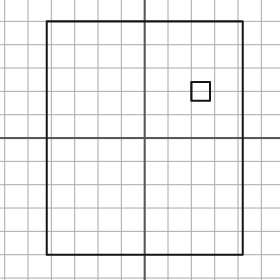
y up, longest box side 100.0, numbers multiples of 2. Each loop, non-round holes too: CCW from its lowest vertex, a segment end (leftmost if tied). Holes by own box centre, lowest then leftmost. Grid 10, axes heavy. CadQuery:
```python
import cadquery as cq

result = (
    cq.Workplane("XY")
    .moveTo(-42.0, -50.0)
    .lineTo(42.0, -50.0)
    .lineTo(42.0, 50.0)
    .lineTo(-42.0, 50.0)
    .close()
    .moveTo(20.0, 16.0)
    .lineTo(28.0, 16.0)
    .lineTo(28.0, 24.0)
    .lineTo(20.0, 24.0)
    .close()
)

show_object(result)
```